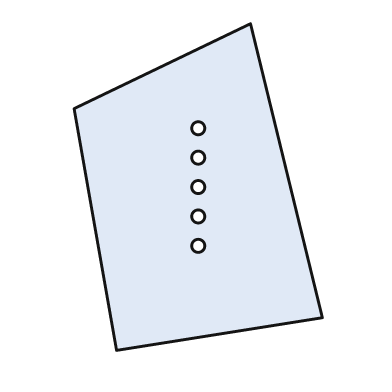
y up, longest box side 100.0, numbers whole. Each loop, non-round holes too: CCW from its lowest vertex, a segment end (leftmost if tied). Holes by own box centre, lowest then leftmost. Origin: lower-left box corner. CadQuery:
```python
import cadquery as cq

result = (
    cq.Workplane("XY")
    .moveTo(13.0, 0.0)
    .lineTo(76.0, 10.0)
    .lineTo(54.0, 100.0)
    .lineTo(0.0, 74.0)
    .close()
    .moveTo(38.0, 32.0)
    .circle(2.0)
    .moveTo(38.0, 41.0)
    .circle(2.0)
    .moveTo(38.0, 50.0)
    .circle(2.0)
    .moveTo(38.0, 59.0)
    .circle(2.0)
    .moveTo(38.0, 68.0)
    .circle(2.0)
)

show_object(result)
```